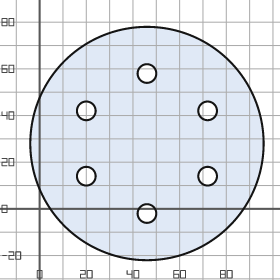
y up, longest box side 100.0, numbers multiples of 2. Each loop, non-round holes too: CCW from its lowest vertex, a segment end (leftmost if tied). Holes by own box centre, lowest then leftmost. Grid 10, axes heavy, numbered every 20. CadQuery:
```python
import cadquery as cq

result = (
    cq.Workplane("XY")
    .moveTo(46.0, 28.0)
    .circle(50.0)
    .moveTo(46.0, -2.0)
    .circle(4.0)
    .moveTo(20.0, 14.0)
    .circle(4.0)
    .moveTo(72.0, 14.0)
    .circle(4.0)
    .moveTo(20.0, 42.0)
    .circle(4.0)
    .moveTo(72.0, 42.0)
    .circle(4.0)
    .moveTo(46.0, 58.0)
    .circle(4.0)
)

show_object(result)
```